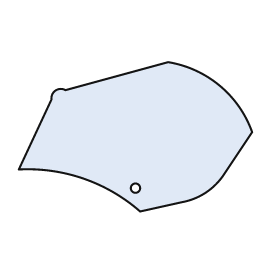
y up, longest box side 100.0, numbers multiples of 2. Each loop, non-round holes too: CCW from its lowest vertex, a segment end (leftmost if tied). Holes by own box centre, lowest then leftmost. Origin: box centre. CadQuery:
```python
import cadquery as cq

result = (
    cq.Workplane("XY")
    .moveTo(2.0, -32.0)
    .lineTo(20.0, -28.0)
    .threePointArc((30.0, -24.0), (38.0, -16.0))
    .lineTo(50.0, 2.0)
    .threePointArc((36.0, 22.0), (14.0, 32.0))
    .lineTo(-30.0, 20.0)
    .threePointArc((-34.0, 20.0), (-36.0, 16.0))
    .lineTo(-50.0, -14.0)
    .threePointArc((-22.0, -18.0), (2.0, -32.0))
    .close()
    .moveTo(0.0, -22.0)
    .circle(2.0)
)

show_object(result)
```